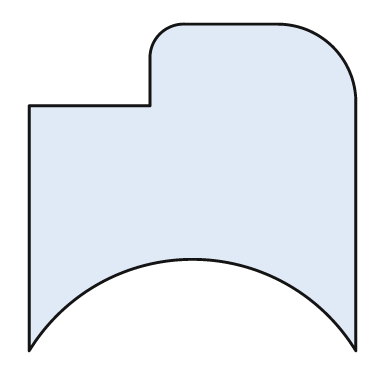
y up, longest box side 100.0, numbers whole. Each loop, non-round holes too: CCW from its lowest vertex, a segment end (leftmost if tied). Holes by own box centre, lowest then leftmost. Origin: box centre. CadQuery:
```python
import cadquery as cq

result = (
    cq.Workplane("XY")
    .moveTo(-50.0, -50.0)
    .threePointArc((0.0, -22.0), (50.0, -50.0))
    .lineTo(50.0, 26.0)
    .threePointArc((43.0, 43.0), (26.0, 50.0))
    .lineTo(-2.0, 50.0)
    .threePointArc((-10.0, 47.0), (-13.0, 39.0))
    .lineTo(-13.0, 25.0)
    .lineTo(-50.0, 25.0)
    .close()
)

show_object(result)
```